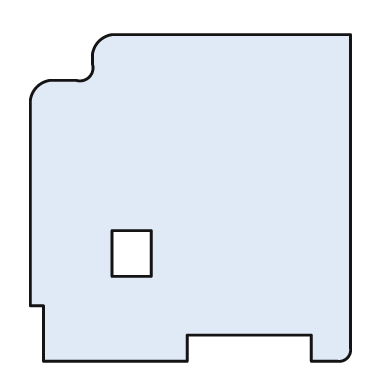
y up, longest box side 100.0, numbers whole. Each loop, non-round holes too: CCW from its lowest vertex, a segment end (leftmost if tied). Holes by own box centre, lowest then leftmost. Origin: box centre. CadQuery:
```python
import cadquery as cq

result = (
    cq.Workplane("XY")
    .moveTo(-45.0, -50.0)
    .lineTo(-1.0, -50.0)
    .lineTo(-1.0, -42.0)
    .lineTo(37.0, -42.0)
    .lineTo(37.0, -50.0)
    .lineTo(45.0, -50.0)
    .threePointArc((48.0, -49.0), (49.0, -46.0))
    .lineTo(49.0, 50.0)
    .lineTo(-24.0, 50.0)
    .threePointArc((-28.0, 48.0), (-30.0, 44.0))
    .lineTo(-30.0, 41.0)
    .threePointArc((-31.0, 37.0), (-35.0, 36.0))
    .lineTo(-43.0, 36.0)
    .threePointArc((-47.0, 34.0), (-49.0, 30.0))
    .lineTo(-49.0, -33.0)
    .lineTo(-45.0, -33.0)
    .close()
    .moveTo(-24.0, -24.0)
    .lineTo(-12.0, -24.0)
    .lineTo(-12.0, -10.0)
    .lineTo(-24.0, -10.0)
    .close()
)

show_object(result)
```